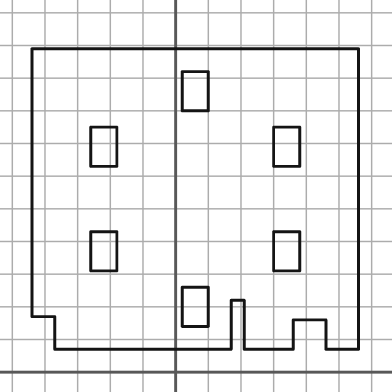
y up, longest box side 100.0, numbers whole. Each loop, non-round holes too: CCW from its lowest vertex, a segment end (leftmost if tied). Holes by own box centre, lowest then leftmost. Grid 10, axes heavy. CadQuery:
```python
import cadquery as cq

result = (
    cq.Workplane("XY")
    .moveTo(-37.0, 7.0)
    .lineTo(17.0, 7.0)
    .lineTo(17.0, 22.0)
    .lineTo(21.0, 22.0)
    .lineTo(21.0, 7.0)
    .lineTo(36.0, 7.0)
    .lineTo(36.0, 16.0)
    .lineTo(46.0, 16.0)
    .lineTo(46.0, 7.0)
    .lineTo(56.0, 7.0)
    .lineTo(56.0, 99.0)
    .lineTo(-44.0, 99.0)
    .lineTo(-44.0, 17.0)
    .lineTo(-37.0, 17.0)
    .close()
    .moveTo(2.0, 14.0)
    .lineTo(10.0, 14.0)
    .lineTo(10.0, 26.0)
    .lineTo(2.0, 26.0)
    .close()
    .moveTo(-26.0, 31.0)
    .lineTo(-18.0, 31.0)
    .lineTo(-18.0, 43.0)
    .lineTo(-26.0, 43.0)
    .close()
    .moveTo(30.0, 31.0)
    .lineTo(38.0, 31.0)
    .lineTo(38.0, 43.0)
    .lineTo(30.0, 43.0)
    .close()
    .moveTo(-26.0, 63.0)
    .lineTo(-18.0, 63.0)
    .lineTo(-18.0, 75.0)
    .lineTo(-26.0, 75.0)
    .close()
    .moveTo(30.0, 63.0)
    .lineTo(38.0, 63.0)
    .lineTo(38.0, 75.0)
    .lineTo(30.0, 75.0)
    .close()
    .moveTo(2.0, 80.0)
    .lineTo(10.0, 80.0)
    .lineTo(10.0, 92.0)
    .lineTo(2.0, 92.0)
    .close()
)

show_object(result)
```